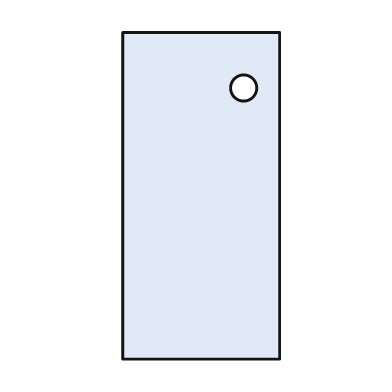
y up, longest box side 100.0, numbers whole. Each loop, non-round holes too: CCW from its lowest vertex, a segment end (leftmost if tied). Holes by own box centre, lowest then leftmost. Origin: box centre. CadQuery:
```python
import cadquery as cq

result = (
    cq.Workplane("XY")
    .moveTo(-24.0, -50.0)
    .lineTo(24.0, -50.0)
    .lineTo(24.0, 50.0)
    .lineTo(-24.0, 50.0)
    .close()
    .moveTo(13.0, 33.0)
    .circle(4.0)
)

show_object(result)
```